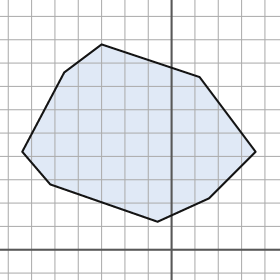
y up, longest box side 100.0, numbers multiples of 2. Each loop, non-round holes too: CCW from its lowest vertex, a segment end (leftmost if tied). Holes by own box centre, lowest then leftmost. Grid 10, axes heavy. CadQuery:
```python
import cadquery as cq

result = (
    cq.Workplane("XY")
    .moveTo(-6.0, 12.0)
    .lineTo(16.0, 22.0)
    .lineTo(36.0, 42.0)
    .lineTo(12.0, 74.0)
    .lineTo(-30.0, 88.0)
    .lineTo(-46.0, 76.0)
    .lineTo(-64.0, 42.0)
    .lineTo(-52.0, 28.0)
    .close()
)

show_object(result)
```